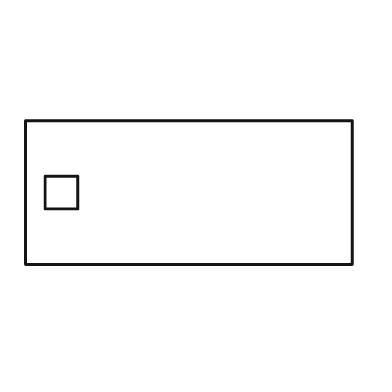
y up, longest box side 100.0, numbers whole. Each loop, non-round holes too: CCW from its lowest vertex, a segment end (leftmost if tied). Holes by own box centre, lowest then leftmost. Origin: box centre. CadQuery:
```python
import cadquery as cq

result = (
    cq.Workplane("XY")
    .moveTo(-50.0, -22.0)
    .lineTo(50.0, -22.0)
    .lineTo(50.0, 22.0)
    .lineTo(-50.0, 22.0)
    .close()
    .moveTo(-44.0, -5.0)
    .lineTo(-34.0, -5.0)
    .lineTo(-34.0, 5.0)
    .lineTo(-44.0, 5.0)
    .close()
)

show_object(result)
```